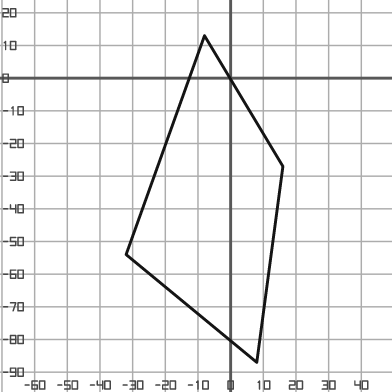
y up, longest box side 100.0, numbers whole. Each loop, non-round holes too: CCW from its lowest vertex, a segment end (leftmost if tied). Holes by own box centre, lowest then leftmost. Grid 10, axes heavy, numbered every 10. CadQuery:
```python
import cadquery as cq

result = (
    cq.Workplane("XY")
    .moveTo(8.0, -87.0)
    .lineTo(16.0, -27.0)
    .lineTo(-8.0, 13.0)
    .lineTo(-32.0, -54.0)
    .close()
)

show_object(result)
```